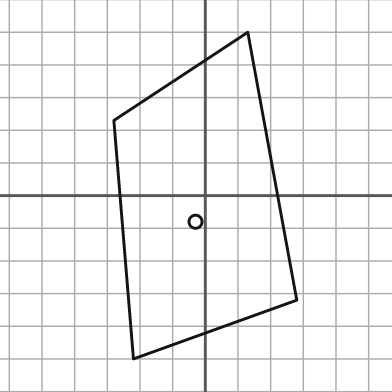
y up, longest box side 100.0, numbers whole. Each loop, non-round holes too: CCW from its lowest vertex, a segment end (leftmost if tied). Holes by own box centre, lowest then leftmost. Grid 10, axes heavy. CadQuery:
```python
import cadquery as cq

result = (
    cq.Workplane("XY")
    .moveTo(-22.0, -50.0)
    .lineTo(28.0, -32.0)
    .lineTo(13.0, 50.0)
    .lineTo(-28.0, 23.0)
    .close()
    .moveTo(-3.0, -8.0)
    .circle(2.0)
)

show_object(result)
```